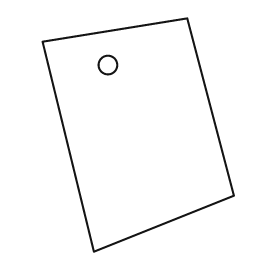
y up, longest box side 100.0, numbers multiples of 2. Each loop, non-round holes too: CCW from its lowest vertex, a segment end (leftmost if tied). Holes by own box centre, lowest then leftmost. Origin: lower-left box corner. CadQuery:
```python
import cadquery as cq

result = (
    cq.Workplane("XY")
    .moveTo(22.0, 0.0)
    .lineTo(82.0, 24.0)
    .lineTo(62.0, 100.0)
    .lineTo(0.0, 90.0)
    .close()
    .moveTo(28.0, 80.0)
    .circle(4.0)
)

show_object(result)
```